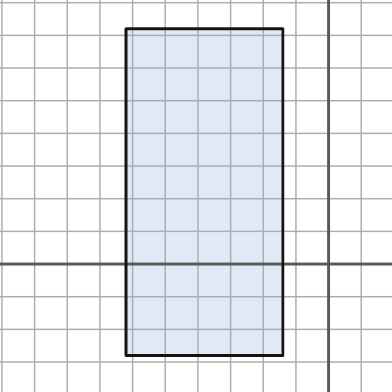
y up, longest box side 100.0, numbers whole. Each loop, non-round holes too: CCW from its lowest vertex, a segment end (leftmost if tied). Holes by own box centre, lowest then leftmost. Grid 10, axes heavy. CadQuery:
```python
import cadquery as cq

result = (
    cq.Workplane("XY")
    .moveTo(-62.0, -28.0)
    .lineTo(-14.0, -28.0)
    .lineTo(-14.0, 72.0)
    .lineTo(-62.0, 72.0)
    .close()
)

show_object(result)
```